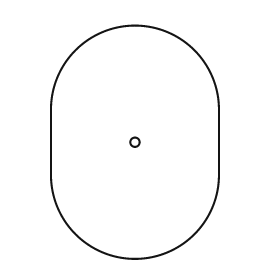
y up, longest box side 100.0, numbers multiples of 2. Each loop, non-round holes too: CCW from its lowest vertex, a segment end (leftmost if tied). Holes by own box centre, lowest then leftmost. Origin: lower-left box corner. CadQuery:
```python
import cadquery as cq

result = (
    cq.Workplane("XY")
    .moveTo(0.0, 36.0)
    .threePointArc((36.0, 0.0), (72.0, 36.0))
    .lineTo(72.0, 64.0)
    .threePointArc((36.0, 100.0), (0.0, 64.0))
    .close()
    .moveTo(36.0, 50.0)
    .circle(2.0)
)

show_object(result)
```